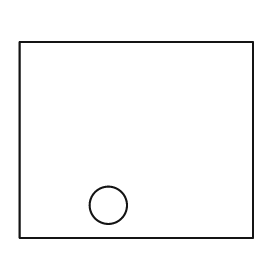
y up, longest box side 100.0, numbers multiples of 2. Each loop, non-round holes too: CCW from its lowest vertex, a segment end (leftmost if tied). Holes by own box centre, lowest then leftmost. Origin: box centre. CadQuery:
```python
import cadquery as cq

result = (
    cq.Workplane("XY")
    .moveTo(-50.0, -42.0)
    .lineTo(50.0, -42.0)
    .lineTo(50.0, 42.0)
    .lineTo(-50.0, 42.0)
    .close()
    .moveTo(-12.0, -28.0)
    .circle(8.0)
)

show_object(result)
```